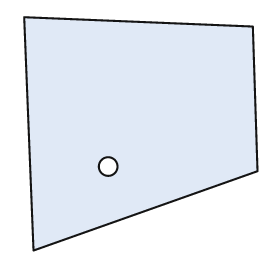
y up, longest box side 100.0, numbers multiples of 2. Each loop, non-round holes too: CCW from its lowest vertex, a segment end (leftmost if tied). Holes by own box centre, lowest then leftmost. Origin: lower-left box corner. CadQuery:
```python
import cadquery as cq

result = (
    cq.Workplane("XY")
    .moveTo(4.0, 0.0)
    .lineTo(100.0, 34.0)
    .lineTo(98.0, 96.0)
    .lineTo(0.0, 100.0)
    .close()
    .moveTo(36.0, 36.0)
    .circle(4.0)
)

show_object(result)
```